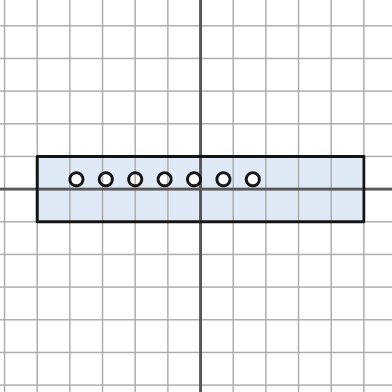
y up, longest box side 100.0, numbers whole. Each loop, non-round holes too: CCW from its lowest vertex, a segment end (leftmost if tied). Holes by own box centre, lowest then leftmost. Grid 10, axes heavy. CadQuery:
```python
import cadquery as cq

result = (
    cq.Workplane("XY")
    .moveTo(-50.0, -10.0)
    .lineTo(50.0, -10.0)
    .lineTo(50.0, 10.0)
    .lineTo(-50.0, 10.0)
    .close()
    .moveTo(-38.0, 3.0)
    .circle(2.0)
    .moveTo(-29.0, 3.0)
    .circle(2.0)
    .moveTo(-20.0, 3.0)
    .circle(2.0)
    .moveTo(-11.0, 3.0)
    .circle(2.0)
    .moveTo(-2.0, 3.0)
    .circle(2.0)
    .moveTo(7.0, 3.0)
    .circle(2.0)
    .moveTo(16.0, 3.0)
    .circle(2.0)
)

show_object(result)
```